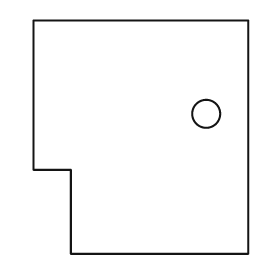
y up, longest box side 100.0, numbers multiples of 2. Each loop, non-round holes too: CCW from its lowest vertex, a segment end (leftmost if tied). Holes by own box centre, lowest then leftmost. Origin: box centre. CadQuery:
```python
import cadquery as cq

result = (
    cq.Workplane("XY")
    .moveTo(-30.0, -50.0)
    .lineTo(46.0, -50.0)
    .lineTo(46.0, 50.0)
    .lineTo(-46.0, 50.0)
    .lineTo(-46.0, -14.0)
    .lineTo(-30.0, -14.0)
    .close()
    .moveTo(28.0, 10.0)
    .circle(6.0)
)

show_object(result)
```